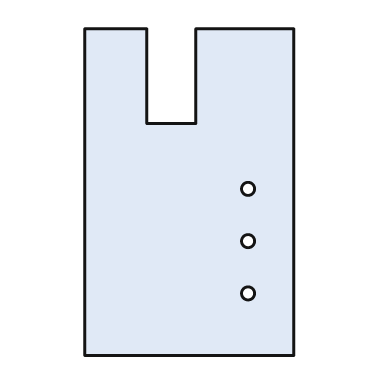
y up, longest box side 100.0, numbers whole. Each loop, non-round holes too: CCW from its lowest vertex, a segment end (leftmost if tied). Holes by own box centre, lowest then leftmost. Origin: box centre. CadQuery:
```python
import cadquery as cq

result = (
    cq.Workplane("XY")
    .moveTo(-32.0, -50.0)
    .lineTo(32.0, -50.0)
    .lineTo(32.0, 50.0)
    .lineTo(2.0, 50.0)
    .lineTo(2.0, 21.0)
    .lineTo(-13.0, 21.0)
    .lineTo(-13.0, 50.0)
    .lineTo(-32.0, 50.0)
    .close()
    .moveTo(18.0, -31.0)
    .circle(2.0)
    .moveTo(18.0, -15.0)
    .circle(2.0)
    .moveTo(18.0, 1.0)
    .circle(2.0)
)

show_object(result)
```